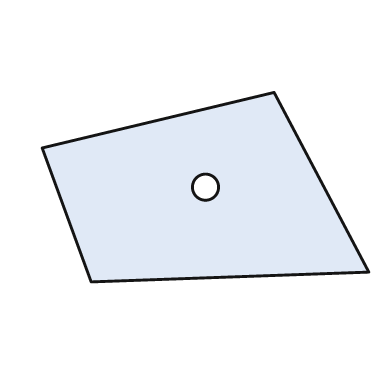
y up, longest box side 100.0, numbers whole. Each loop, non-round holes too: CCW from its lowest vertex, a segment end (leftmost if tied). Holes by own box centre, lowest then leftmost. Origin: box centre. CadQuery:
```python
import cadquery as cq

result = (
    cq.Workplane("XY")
    .moveTo(-35.0, -29.0)
    .lineTo(50.0, -26.0)
    .lineTo(21.0, 29.0)
    .lineTo(-50.0, 12.0)
    .close()
    .moveTo(0.0, 0.0)
    .circle(4.0)
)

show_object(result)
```